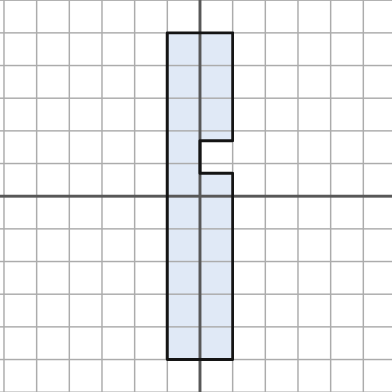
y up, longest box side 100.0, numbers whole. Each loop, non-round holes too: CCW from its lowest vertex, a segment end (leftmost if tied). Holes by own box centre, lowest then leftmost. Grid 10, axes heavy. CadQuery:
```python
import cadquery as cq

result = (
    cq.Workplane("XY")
    .moveTo(-10.0, -50.0)
    .lineTo(10.0, -50.0)
    .lineTo(10.0, 7.0)
    .lineTo(0.0, 7.0)
    .lineTo(0.0, 17.0)
    .lineTo(10.0, 17.0)
    .lineTo(10.0, 50.0)
    .lineTo(-10.0, 50.0)
    .close()
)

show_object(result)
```